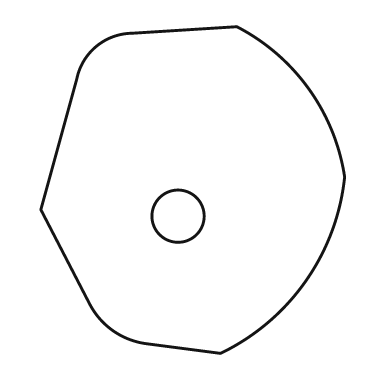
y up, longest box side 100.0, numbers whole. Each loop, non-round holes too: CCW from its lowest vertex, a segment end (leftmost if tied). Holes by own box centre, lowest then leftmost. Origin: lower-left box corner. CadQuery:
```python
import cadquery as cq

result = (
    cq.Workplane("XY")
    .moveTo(55.0, 0.0)
    .threePointArc((81.0, 22.0), (93.0, 54.0))
    .threePointArc((82.0, 81.0), (60.0, 100.0))
    .lineTo(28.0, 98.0)
    .threePointArc((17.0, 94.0), (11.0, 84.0))
    .lineTo(0.0, 44.0)
    .lineTo(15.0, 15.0)
    .threePointArc((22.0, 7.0), (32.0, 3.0))
    .close()
    .moveTo(42.0, 42.0)
    .circle(8.0)
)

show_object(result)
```